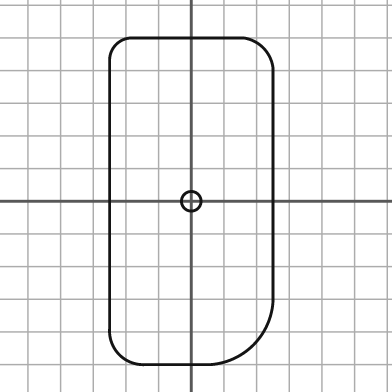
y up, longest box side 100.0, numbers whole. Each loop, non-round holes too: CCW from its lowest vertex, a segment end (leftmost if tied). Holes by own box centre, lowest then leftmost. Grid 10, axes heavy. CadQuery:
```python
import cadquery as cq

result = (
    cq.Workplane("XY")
    .moveTo(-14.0, -50.0)
    .lineTo(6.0, -50.0)
    .threePointArc((19.0, -44.0), (25.0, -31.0))
    .lineTo(25.0, 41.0)
    .threePointArc((22.0, 47.0), (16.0, 50.0))
    .lineTo(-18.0, 50.0)
    .threePointArc((-23.0, 48.0), (-25.0, 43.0))
    .lineTo(-25.0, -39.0)
    .threePointArc((-22.0, -47.0), (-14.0, -50.0))
    .close()
    .moveTo(0.0, 0.0)
    .circle(3.0)
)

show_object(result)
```